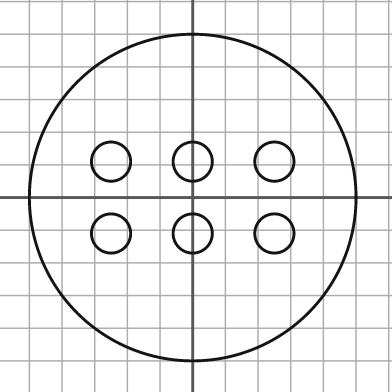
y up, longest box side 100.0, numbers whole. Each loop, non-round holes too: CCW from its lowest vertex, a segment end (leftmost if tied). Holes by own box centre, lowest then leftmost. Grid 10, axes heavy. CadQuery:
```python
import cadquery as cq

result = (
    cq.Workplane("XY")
    .moveTo(0.0, 0.0)
    .circle(50.0)
    .moveTo(-25.0, -11.0)
    .circle(6.0)
    .moveTo(0.0, -11.0)
    .circle(6.0)
    .moveTo(25.0, -11.0)
    .circle(6.0)
    .moveTo(-25.0, 11.0)
    .circle(6.0)
    .moveTo(0.0, 11.0)
    .circle(6.0)
    .moveTo(25.0, 11.0)
    .circle(6.0)
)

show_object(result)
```